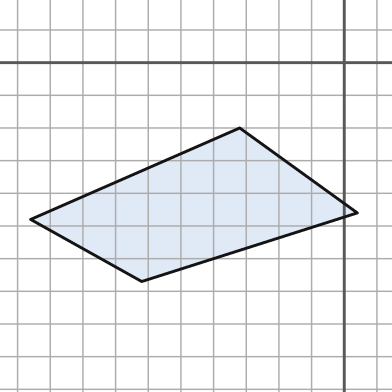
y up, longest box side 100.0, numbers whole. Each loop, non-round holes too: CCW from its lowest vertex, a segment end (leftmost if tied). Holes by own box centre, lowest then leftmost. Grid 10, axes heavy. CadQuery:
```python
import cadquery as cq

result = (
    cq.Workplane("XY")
    .moveTo(-62.0, -67.0)
    .lineTo(4.0, -46.0)
    .lineTo(-32.0, -20.0)
    .lineTo(-96.0, -48.0)
    .close()
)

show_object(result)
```